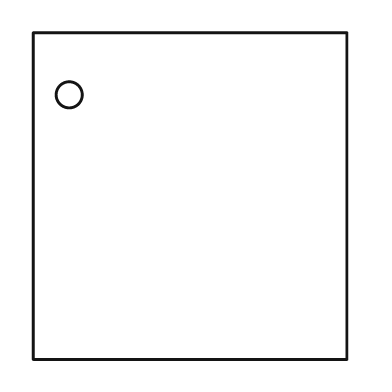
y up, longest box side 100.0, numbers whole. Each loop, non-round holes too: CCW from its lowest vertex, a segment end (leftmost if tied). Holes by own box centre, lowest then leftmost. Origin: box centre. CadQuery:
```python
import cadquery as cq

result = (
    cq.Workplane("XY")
    .moveTo(-48.0, -50.0)
    .lineTo(48.0, -50.0)
    .lineTo(48.0, 50.0)
    .lineTo(-48.0, 50.0)
    .close()
    .moveTo(-37.0, 31.0)
    .circle(4.0)
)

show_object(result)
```